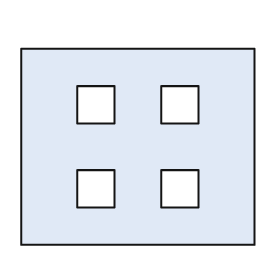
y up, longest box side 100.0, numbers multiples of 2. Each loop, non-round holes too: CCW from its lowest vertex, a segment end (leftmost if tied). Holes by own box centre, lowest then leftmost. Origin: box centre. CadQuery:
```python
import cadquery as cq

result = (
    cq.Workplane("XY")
    .moveTo(-50.0, -42.0)
    .lineTo(50.0, -42.0)
    .lineTo(50.0, 42.0)
    .lineTo(-50.0, 42.0)
    .close()
    .moveTo(-26.0, -26.0)
    .lineTo(-10.0, -26.0)
    .lineTo(-10.0, -10.0)
    .lineTo(-26.0, -10.0)
    .close()
    .moveTo(10.0, -26.0)
    .lineTo(26.0, -26.0)
    .lineTo(26.0, -10.0)
    .lineTo(10.0, -10.0)
    .close()
    .moveTo(-26.0, 10.0)
    .lineTo(-10.0, 10.0)
    .lineTo(-10.0, 26.0)
    .lineTo(-26.0, 26.0)
    .close()
    .moveTo(10.0, 10.0)
    .lineTo(26.0, 10.0)
    .lineTo(26.0, 26.0)
    .lineTo(10.0, 26.0)
    .close()
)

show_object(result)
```